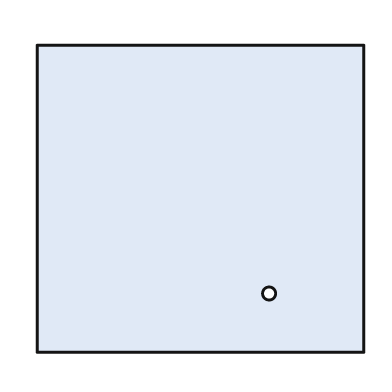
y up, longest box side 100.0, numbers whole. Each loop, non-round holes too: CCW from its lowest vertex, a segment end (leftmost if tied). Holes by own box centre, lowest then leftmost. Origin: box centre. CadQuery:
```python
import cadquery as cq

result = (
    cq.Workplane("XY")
    .moveTo(-50.0, -47.0)
    .lineTo(50.0, -47.0)
    .lineTo(50.0, 47.0)
    .lineTo(-50.0, 47.0)
    .close()
    .moveTo(21.0, -29.0)
    .circle(2.0)
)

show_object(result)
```